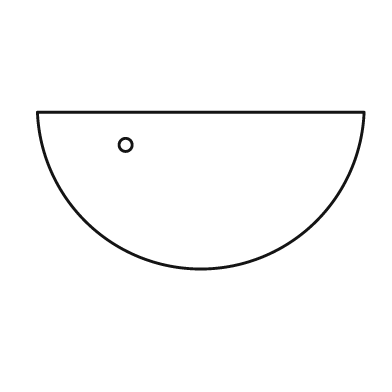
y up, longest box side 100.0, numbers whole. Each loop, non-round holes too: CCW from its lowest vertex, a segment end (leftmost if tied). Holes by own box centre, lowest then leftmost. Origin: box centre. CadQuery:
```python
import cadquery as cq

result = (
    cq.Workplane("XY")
    .moveTo(-50.0, 24.0)
    .threePointArc((0.0, -24.0), (50.0, 24.0))
    .close()
    .moveTo(-23.0, 14.0)
    .circle(2.0)
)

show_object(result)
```